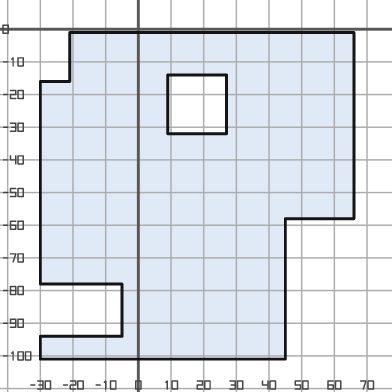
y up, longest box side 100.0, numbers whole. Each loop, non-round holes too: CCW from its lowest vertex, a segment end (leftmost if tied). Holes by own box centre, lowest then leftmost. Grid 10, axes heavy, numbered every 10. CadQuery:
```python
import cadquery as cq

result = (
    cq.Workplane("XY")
    .moveTo(-30.0, -101.0)
    .lineTo(45.0, -101.0)
    .lineTo(45.0, -58.0)
    .lineTo(66.0, -58.0)
    .lineTo(66.0, -1.0)
    .lineTo(-21.0, -1.0)
    .lineTo(-21.0, -16.0)
    .lineTo(-30.0, -16.0)
    .lineTo(-30.0, -78.0)
    .lineTo(-5.0, -78.0)
    .lineTo(-5.0, -94.0)
    .lineTo(-30.0, -94.0)
    .close()
    .moveTo(9.0, -32.0)
    .lineTo(27.0, -32.0)
    .lineTo(27.0, -14.0)
    .lineTo(9.0, -14.0)
    .close()
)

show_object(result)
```